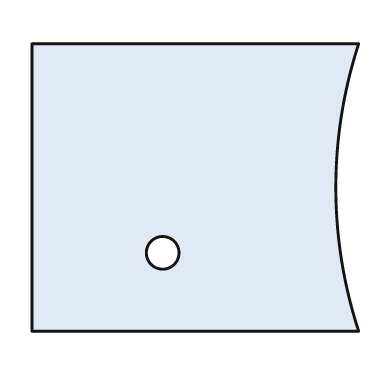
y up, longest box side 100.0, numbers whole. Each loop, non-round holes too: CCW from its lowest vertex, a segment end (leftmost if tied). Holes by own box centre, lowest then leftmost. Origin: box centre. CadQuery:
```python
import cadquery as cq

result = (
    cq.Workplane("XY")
    .moveTo(-50.0, -44.0)
    .lineTo(50.0, -44.0)
    .threePointArc((43.0, 0.0), (50.0, 44.0))
    .lineTo(-50.0, 44.0)
    .close()
    .moveTo(-10.0, -20.0)
    .circle(5.0)
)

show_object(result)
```